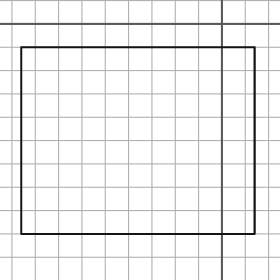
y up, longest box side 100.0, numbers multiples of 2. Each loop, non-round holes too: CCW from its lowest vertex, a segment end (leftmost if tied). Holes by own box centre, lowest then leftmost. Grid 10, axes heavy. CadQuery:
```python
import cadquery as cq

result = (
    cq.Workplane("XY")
    .moveTo(-86.0, -90.0)
    .lineTo(14.0, -90.0)
    .lineTo(14.0, -10.0)
    .lineTo(-86.0, -10.0)
    .close()
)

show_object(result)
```